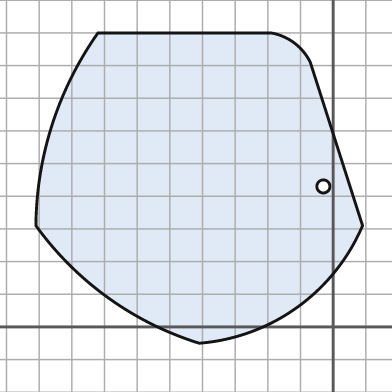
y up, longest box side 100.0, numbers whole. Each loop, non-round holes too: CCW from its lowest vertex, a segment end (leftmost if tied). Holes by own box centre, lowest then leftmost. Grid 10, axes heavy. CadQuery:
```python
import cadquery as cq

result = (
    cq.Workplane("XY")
    .moveTo(-41.0, -5.0)
    .threePointArc((-11.0, 6.0), (9.0, 31.0))
    .lineTo(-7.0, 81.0)
    .threePointArc((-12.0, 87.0), (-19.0, 90.0))
    .lineTo(-72.0, 90.0)
    .threePointArc((-86.0, 62.0), (-91.0, 31.0))
    .threePointArc((-69.0, 9.0), (-41.0, -5.0))
    .close()
    .moveTo(-3.0, 43.0)
    .circle(2.0)
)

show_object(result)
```